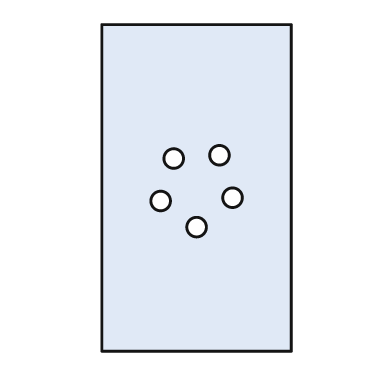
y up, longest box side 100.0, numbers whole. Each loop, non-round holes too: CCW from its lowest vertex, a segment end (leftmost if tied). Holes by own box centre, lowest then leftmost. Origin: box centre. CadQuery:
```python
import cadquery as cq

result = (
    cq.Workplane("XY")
    .moveTo(-29.0, -50.0)
    .lineTo(29.0, -50.0)
    .lineTo(29.0, 50.0)
    .lineTo(-29.0, 50.0)
    .close()
    .moveTo(0.0, -12.0)
    .circle(3.0)
    .moveTo(-11.0, -4.0)
    .circle(3.0)
    .moveTo(11.0, -3.0)
    .circle(3.0)
    .moveTo(-7.0, 9.0)
    .circle(3.0)
    .moveTo(7.0, 10.0)
    .circle(3.0)
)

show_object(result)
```